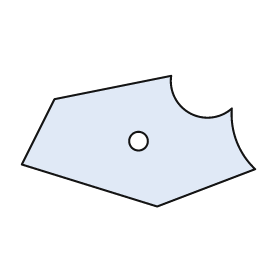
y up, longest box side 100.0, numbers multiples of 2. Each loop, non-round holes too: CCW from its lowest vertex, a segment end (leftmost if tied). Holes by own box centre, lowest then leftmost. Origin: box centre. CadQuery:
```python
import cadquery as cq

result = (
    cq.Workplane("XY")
    .moveTo(8.0, -28.0)
    .lineTo(50.0, -12.0)
    .threePointArc((42.0, 0.0), (40.0, 14.0))
    .threePointArc((22.0, 12.0), (14.0, 28.0))
    .lineTo(-36.0, 18.0)
    .lineTo(-50.0, -10.0)
    .close()
    .moveTo(0.0, 0.0)
    .circle(4.0)
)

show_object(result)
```